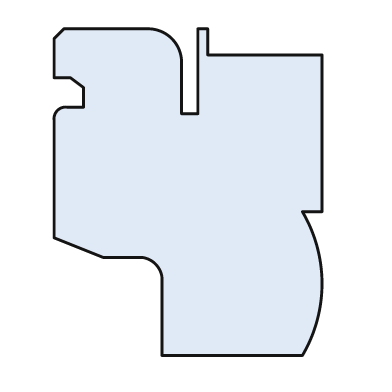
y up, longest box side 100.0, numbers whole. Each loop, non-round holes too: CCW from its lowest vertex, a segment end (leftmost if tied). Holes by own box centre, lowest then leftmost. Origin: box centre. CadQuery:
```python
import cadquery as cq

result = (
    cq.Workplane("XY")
    .moveTo(-8.0, -50.0)
    .lineTo(35.0, -50.0)
    .threePointArc((41.0, -28.0), (35.0, -6.0))
    .lineTo(41.0, -6.0)
    .lineTo(41.0, 42.0)
    .lineTo(6.0, 42.0)
    .lineTo(6.0, 50.0)
    .lineTo(3.0, 50.0)
    .lineTo(3.0, 24.0)
    .lineTo(-2.0, 24.0)
    .lineTo(-2.0, 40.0)
    .threePointArc((-5.0, 47.0), (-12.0, 50.0))
    .lineTo(-38.0, 50.0)
    .lineTo(-41.0, 47.0)
    .lineTo(-41.0, 35.0)
    .lineTo(-36.0, 35.0)
    .lineTo(-32.0, 32.0)
    .lineTo(-32.0, 26.0)
    .lineTo(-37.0, 26.0)
    .threePointArc((-40.0, 25.0), (-41.0, 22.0))
    .lineTo(-41.0, -14.0)
    .lineTo(-26.0, -20.0)
    .lineTo(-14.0, -20.0)
    .threePointArc((-10.0, -22.0), (-8.0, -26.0))
    .close()
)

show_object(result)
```